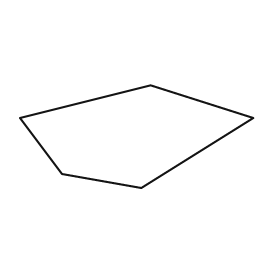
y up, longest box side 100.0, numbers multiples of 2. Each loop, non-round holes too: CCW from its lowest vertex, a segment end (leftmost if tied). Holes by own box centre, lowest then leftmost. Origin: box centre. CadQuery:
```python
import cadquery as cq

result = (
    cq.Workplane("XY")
    .moveTo(2.0, -22.0)
    .lineTo(50.0, 8.0)
    .lineTo(6.0, 22.0)
    .lineTo(-50.0, 8.0)
    .lineTo(-32.0, -16.0)
    .close()
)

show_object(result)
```